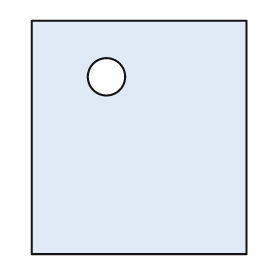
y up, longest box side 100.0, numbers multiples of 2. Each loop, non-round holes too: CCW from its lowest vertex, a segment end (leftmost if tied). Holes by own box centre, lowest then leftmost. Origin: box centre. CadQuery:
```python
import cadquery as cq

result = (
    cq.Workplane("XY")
    .moveTo(-46.0, -50.0)
    .lineTo(46.0, -50.0)
    .lineTo(46.0, 50.0)
    .lineTo(-46.0, 50.0)
    .close()
    .moveTo(-14.0, 26.0)
    .circle(8.0)
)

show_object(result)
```